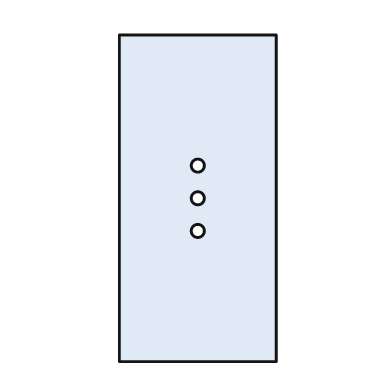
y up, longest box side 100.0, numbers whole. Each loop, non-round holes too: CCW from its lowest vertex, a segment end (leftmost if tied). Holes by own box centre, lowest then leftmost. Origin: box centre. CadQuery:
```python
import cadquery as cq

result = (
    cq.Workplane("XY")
    .moveTo(-24.0, -50.0)
    .lineTo(24.0, -50.0)
    .lineTo(24.0, 50.0)
    .lineTo(-24.0, 50.0)
    .close()
    .moveTo(0.0, -10.0)
    .circle(2.0)
    .moveTo(0.0, 0.0)
    .circle(2.0)
    .moveTo(0.0, 10.0)
    .circle(2.0)
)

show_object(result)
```